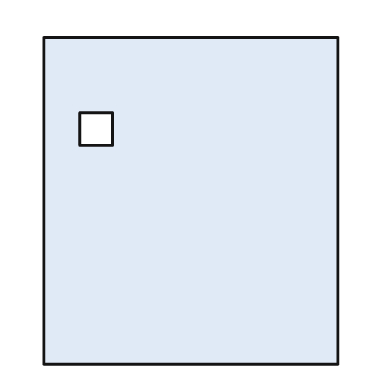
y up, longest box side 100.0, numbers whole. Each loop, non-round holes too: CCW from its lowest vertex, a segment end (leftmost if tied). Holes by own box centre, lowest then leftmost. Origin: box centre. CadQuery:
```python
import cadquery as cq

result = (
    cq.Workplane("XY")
    .moveTo(-45.0, -50.0)
    .lineTo(45.0, -50.0)
    .lineTo(45.0, 50.0)
    .lineTo(-45.0, 50.0)
    .close()
    .moveTo(-34.0, 17.0)
    .lineTo(-24.0, 17.0)
    .lineTo(-24.0, 27.0)
    .lineTo(-34.0, 27.0)
    .close()
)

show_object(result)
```